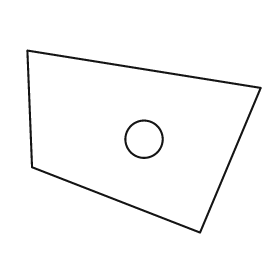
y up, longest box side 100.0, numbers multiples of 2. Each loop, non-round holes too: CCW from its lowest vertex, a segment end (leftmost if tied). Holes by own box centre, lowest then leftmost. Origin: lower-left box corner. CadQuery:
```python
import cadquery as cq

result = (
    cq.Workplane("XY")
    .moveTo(74.0, 0.0)
    .lineTo(100.0, 62.0)
    .lineTo(0.0, 78.0)
    .lineTo(2.0, 28.0)
    .close()
    .moveTo(50.0, 40.0)
    .circle(8.0)
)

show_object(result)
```